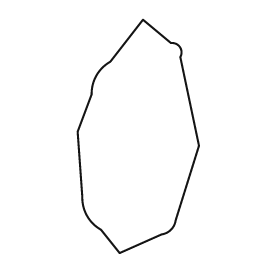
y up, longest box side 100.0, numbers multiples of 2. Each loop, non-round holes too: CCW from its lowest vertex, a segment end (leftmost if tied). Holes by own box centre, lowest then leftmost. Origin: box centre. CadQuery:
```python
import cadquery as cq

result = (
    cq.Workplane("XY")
    .moveTo(-8.0, -50.0)
    .lineTo(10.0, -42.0)
    .threePointArc((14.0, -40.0), (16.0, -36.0))
    .lineTo(26.0, -4.0)
    .lineTo(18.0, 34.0)
    .threePointArc((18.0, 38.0), (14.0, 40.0))
    .lineTo(2.0, 50.0)
    .lineTo(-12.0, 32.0)
    .threePointArc((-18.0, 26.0), (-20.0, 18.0))
    .lineTo(-26.0, 2.0)
    .lineTo(-24.0, -26.0)
    .threePointArc((-22.0, -34.0), (-16.0, -40.0))
    .close()
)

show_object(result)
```